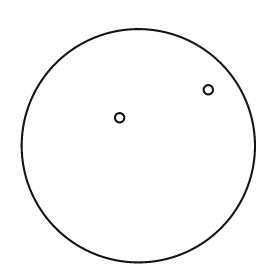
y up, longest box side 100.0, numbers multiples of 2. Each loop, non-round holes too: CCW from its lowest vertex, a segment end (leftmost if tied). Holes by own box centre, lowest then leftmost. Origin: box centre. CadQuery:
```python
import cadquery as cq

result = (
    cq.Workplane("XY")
    .moveTo(0.0, 0.0)
    .circle(50.0)
    .moveTo(-8.0, 12.0)
    .circle(2.0)
    .moveTo(30.0, 24.0)
    .circle(2.0)
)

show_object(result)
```